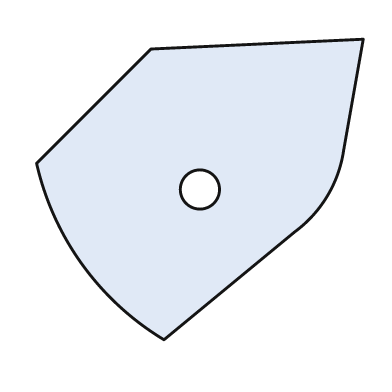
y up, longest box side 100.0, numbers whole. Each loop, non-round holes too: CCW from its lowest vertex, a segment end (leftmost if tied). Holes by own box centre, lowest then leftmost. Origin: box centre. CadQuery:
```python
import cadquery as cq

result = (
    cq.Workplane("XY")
    .moveTo(-11.0, -46.0)
    .lineTo(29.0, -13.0)
    .threePointArc((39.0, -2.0), (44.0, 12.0))
    .lineTo(50.0, 46.0)
    .lineTo(-15.0, 43.0)
    .lineTo(-50.0, 8.0)
    .threePointArc((-36.0, -23.0), (-11.0, -46.0))
    .close()
    .moveTo(0.0, 0.0)
    .circle(6.0)
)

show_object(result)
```